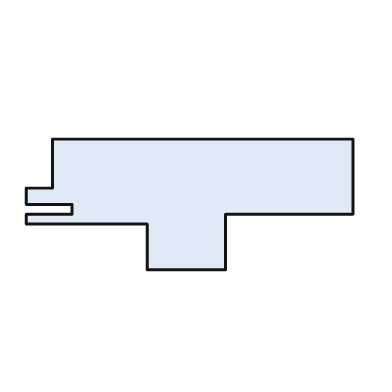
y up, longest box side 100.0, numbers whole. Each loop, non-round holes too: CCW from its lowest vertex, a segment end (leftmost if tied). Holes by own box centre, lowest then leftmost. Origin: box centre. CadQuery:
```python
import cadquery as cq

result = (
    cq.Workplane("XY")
    .moveTo(-13.0, -20.0)
    .lineTo(11.0, -20.0)
    .lineTo(11.0, -3.0)
    .lineTo(50.0, -3.0)
    .lineTo(50.0, 20.0)
    .lineTo(-42.0, 20.0)
    .lineTo(-42.0, 5.0)
    .lineTo(-50.0, 5.0)
    .lineTo(-50.0, 0.0)
    .lineTo(-36.0, 0.0)
    .lineTo(-36.0, -3.0)
    .lineTo(-50.0, -3.0)
    .lineTo(-50.0, -6.0)
    .lineTo(-13.0, -6.0)
    .close()
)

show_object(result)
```